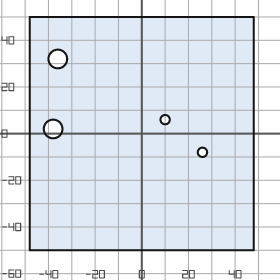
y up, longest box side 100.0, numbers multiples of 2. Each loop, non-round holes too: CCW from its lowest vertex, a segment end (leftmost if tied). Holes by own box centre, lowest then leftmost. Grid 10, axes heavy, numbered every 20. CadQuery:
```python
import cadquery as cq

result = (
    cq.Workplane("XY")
    .moveTo(-48.0, -50.0)
    .lineTo(48.0, -50.0)
    .lineTo(48.0, 50.0)
    .lineTo(-48.0, 50.0)
    .close()
    .moveTo(26.0, -8.0)
    .circle(2.0)
    .moveTo(-38.0, 2.0)
    .circle(4.0)
    .moveTo(10.0, 6.0)
    .circle(2.0)
    .moveTo(-36.0, 32.0)
    .circle(4.0)
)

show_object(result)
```